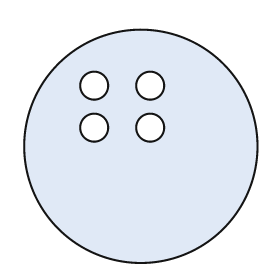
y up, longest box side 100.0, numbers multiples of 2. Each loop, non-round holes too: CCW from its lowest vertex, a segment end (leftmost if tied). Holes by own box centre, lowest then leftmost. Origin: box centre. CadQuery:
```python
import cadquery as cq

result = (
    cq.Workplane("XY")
    .moveTo(0.0, 0.0)
    .circle(50.0)
    .moveTo(-20.0, 8.0)
    .circle(6.0)
    .moveTo(4.0, 8.0)
    .circle(6.0)
    .moveTo(-20.0, 26.0)
    .circle(6.0)
    .moveTo(4.0, 26.0)
    .circle(6.0)
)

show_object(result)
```